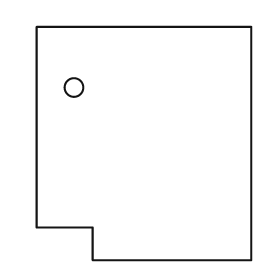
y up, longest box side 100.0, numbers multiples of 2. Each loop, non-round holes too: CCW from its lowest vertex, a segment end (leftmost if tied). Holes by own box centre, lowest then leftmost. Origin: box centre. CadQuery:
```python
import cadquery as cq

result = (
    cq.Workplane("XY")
    .moveTo(-22.0, -50.0)
    .lineTo(46.0, -50.0)
    .lineTo(46.0, 50.0)
    .lineTo(-46.0, 50.0)
    .lineTo(-46.0, -36.0)
    .lineTo(-22.0, -36.0)
    .close()
    .moveTo(-30.0, 24.0)
    .circle(4.0)
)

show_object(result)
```